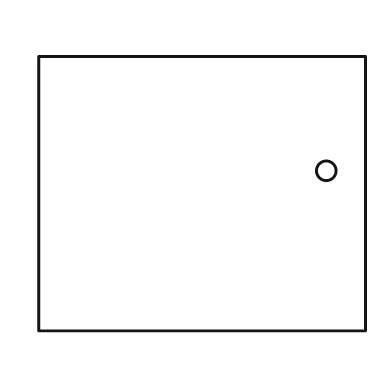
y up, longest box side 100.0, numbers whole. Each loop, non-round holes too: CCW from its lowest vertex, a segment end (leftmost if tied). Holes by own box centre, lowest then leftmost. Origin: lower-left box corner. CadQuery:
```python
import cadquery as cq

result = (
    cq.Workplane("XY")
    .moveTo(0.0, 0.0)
    .lineTo(100.0, 0.0)
    .lineTo(100.0, 84.0)
    .lineTo(0.0, 84.0)
    .close()
    .moveTo(88.0, 49.0)
    .circle(3.0)
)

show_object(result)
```